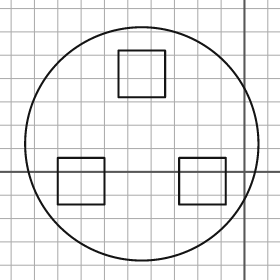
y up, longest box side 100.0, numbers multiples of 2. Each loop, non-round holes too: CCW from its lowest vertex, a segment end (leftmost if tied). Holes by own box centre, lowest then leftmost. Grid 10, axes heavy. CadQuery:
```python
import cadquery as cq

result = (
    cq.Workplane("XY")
    .moveTo(-44.0, 12.0)
    .circle(50.0)
    .moveTo(-80.0, -14.0)
    .lineTo(-60.0, -14.0)
    .lineTo(-60.0, 6.0)
    .lineTo(-80.0, 6.0)
    .close()
    .moveTo(-28.0, -14.0)
    .lineTo(-8.0, -14.0)
    .lineTo(-8.0, 6.0)
    .lineTo(-28.0, 6.0)
    .close()
    .moveTo(-54.0, 32.0)
    .lineTo(-34.0, 32.0)
    .lineTo(-34.0, 52.0)
    .lineTo(-54.0, 52.0)
    .close()
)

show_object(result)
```